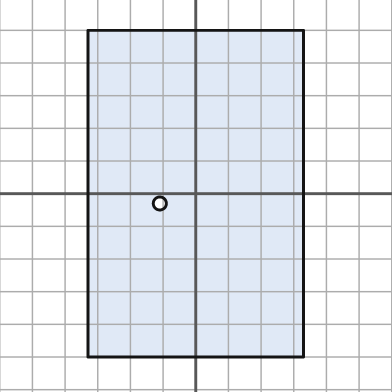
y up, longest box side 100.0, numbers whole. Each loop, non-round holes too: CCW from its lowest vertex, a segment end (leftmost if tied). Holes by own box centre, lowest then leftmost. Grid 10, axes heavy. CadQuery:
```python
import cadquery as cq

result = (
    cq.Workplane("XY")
    .moveTo(-33.0, -50.0)
    .lineTo(33.0, -50.0)
    .lineTo(33.0, 50.0)
    .lineTo(-33.0, 50.0)
    .close()
    .moveTo(-11.0, -3.0)
    .circle(2.0)
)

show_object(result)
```